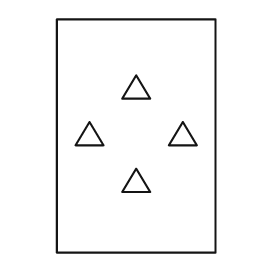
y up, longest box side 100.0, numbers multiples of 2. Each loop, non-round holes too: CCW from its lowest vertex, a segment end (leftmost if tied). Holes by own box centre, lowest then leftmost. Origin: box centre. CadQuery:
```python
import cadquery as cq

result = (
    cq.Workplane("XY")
    .moveTo(-34.0, -50.0)
    .lineTo(34.0, -50.0)
    .lineTo(34.0, 50.0)
    .lineTo(-34.0, 50.0)
    .close()
    .moveTo(-6.0, -24.0)
    .lineTo(6.0, -24.0)
    .lineTo(0.0, -14.0)
    .close()
    .moveTo(-26.0, -4.0)
    .lineTo(-14.0, -4.0)
    .lineTo(-20.0, 6.0)
    .close()
    .moveTo(14.0, -4.0)
    .lineTo(26.0, -4.0)
    .lineTo(20.0, 6.0)
    .close()
    .moveTo(-6.0, 16.0)
    .lineTo(6.0, 16.0)
    .lineTo(0.0, 26.0)
    .close()
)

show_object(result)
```